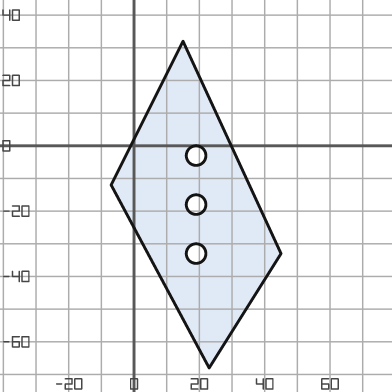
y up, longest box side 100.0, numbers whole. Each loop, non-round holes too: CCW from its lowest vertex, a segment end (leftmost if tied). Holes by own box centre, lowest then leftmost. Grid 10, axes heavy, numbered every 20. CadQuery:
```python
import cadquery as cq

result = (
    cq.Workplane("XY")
    .moveTo(23.0, -68.0)
    .lineTo(45.0, -33.0)
    .lineTo(15.0, 32.0)
    .lineTo(-7.0, -12.0)
    .close()
    .moveTo(19.0, -33.0)
    .circle(3.0)
    .moveTo(19.0, -18.0)
    .circle(3.0)
    .moveTo(19.0, -3.0)
    .circle(3.0)
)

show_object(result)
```